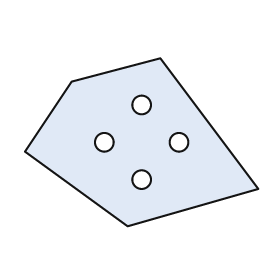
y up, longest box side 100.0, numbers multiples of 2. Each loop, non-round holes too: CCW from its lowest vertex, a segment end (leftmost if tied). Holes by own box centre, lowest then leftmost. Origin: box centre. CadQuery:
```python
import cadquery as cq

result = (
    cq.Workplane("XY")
    .moveTo(-6.0, -36.0)
    .lineTo(50.0, -20.0)
    .lineTo(8.0, 36.0)
    .lineTo(-30.0, 26.0)
    .lineTo(-50.0, -4.0)
    .close()
    .moveTo(0.0, -16.0)
    .circle(4.0)
    .moveTo(-16.0, 0.0)
    .circle(4.0)
    .moveTo(16.0, 0.0)
    .circle(4.0)
    .moveTo(0.0, 16.0)
    .circle(4.0)
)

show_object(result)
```